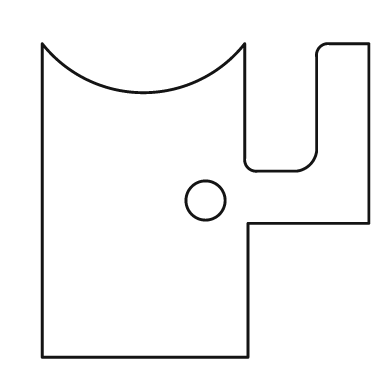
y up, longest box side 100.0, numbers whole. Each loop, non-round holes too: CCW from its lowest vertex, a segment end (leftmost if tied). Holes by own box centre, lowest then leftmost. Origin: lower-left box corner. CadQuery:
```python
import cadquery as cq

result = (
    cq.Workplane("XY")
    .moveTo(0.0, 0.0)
    .lineTo(63.0, 0.0)
    .lineTo(63.0, 41.0)
    .lineTo(100.0, 41.0)
    .lineTo(100.0, 96.0)
    .lineTo(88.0, 96.0)
    .threePointArc((85.0, 95.0), (84.0, 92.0))
    .lineTo(84.0, 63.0)
    .threePointArc((82.0, 59.0), (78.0, 57.0))
    .lineTo(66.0, 57.0)
    .threePointArc((63.0, 58.0), (62.0, 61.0))
    .lineTo(62.0, 96.0)
    .threePointArc((31.0, 81.0), (0.0, 96.0))
    .close()
    .moveTo(50.0, 48.0)
    .circle(6.0)
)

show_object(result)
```